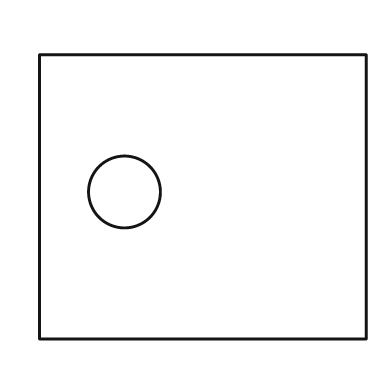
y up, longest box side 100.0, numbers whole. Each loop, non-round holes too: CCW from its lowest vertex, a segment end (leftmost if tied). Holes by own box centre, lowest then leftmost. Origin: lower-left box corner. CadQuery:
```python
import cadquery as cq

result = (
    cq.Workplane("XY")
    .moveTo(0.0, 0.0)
    .lineTo(100.0, 0.0)
    .lineTo(100.0, 87.0)
    .lineTo(0.0, 87.0)
    .close()
    .moveTo(26.0, 45.0)
    .circle(11.0)
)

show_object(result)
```